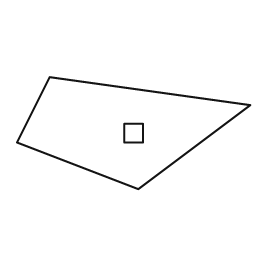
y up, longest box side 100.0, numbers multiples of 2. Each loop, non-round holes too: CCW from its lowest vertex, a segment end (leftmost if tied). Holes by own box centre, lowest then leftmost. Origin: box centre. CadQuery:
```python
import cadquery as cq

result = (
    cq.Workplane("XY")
    .moveTo(2.0, -24.0)
    .lineTo(50.0, 12.0)
    .lineTo(-36.0, 24.0)
    .lineTo(-50.0, -4.0)
    .close()
    .moveTo(-4.0, -4.0)
    .lineTo(4.0, -4.0)
    .lineTo(4.0, 4.0)
    .lineTo(-4.0, 4.0)
    .close()
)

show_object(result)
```